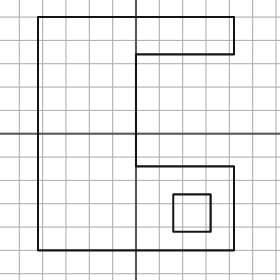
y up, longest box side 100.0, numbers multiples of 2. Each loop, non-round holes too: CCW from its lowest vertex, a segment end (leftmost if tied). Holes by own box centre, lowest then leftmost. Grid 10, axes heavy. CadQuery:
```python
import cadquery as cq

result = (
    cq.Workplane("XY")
    .moveTo(-42.0, -50.0)
    .lineTo(42.0, -50.0)
    .lineTo(42.0, -14.0)
    .lineTo(0.0, -14.0)
    .lineTo(0.0, 34.0)
    .lineTo(42.0, 34.0)
    .lineTo(42.0, 50.0)
    .lineTo(-42.0, 50.0)
    .close()
    .moveTo(16.0, -42.0)
    .lineTo(32.0, -42.0)
    .lineTo(32.0, -26.0)
    .lineTo(16.0, -26.0)
    .close()
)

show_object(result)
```